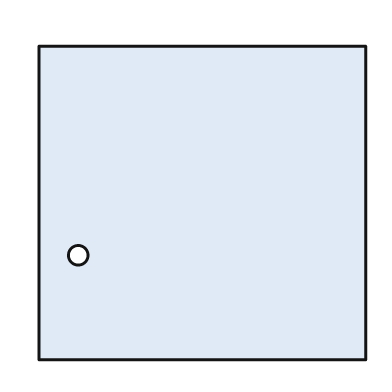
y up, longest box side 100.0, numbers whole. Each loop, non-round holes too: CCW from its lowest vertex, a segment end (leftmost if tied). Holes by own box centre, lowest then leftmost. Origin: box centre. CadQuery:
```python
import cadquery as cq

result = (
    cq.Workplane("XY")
    .moveTo(-50.0, -48.0)
    .lineTo(50.0, -48.0)
    .lineTo(50.0, 48.0)
    .lineTo(-50.0, 48.0)
    .close()
    .moveTo(-38.0, -16.0)
    .circle(3.0)
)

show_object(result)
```